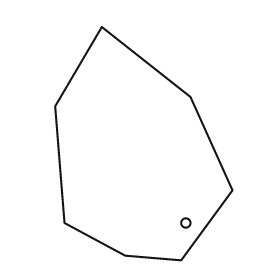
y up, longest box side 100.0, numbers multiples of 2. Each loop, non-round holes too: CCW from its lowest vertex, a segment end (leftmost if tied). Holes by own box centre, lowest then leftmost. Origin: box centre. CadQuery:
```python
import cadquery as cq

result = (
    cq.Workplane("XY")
    .moveTo(16.0, -50.0)
    .lineTo(38.0, -20.0)
    .lineTo(20.0, 20.0)
    .lineTo(-18.0, 50.0)
    .lineTo(-38.0, 16.0)
    .lineTo(-34.0, -34.0)
    .lineTo(-8.0, -48.0)
    .close()
    .moveTo(18.0, -34.0)
    .circle(2.0)
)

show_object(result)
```